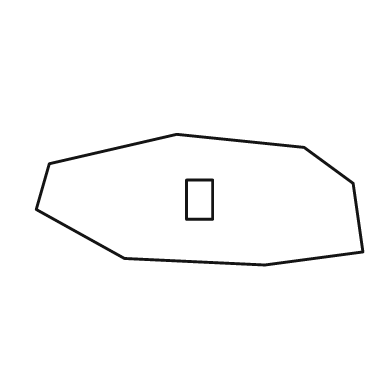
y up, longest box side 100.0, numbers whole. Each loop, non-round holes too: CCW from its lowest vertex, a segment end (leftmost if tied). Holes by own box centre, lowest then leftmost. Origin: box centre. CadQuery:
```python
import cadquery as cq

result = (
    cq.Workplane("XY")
    .moveTo(20.0, -20.0)
    .lineTo(50.0, -16.0)
    .lineTo(47.0, 5.0)
    .lineTo(32.0, 16.0)
    .lineTo(-7.0, 20.0)
    .lineTo(-46.0, 11.0)
    .lineTo(-50.0, -3.0)
    .lineTo(-23.0, -18.0)
    .close()
    .moveTo(-4.0, -6.0)
    .lineTo(4.0, -6.0)
    .lineTo(4.0, 6.0)
    .lineTo(-4.0, 6.0)
    .close()
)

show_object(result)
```